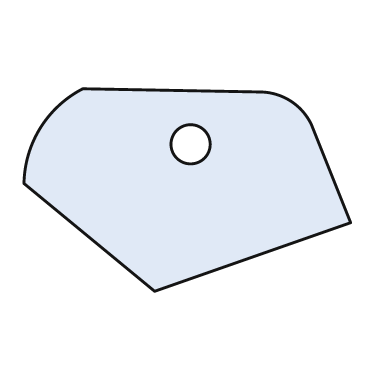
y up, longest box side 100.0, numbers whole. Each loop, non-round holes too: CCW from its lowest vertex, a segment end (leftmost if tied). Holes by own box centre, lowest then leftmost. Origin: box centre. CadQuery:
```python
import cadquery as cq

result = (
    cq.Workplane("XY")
    .moveTo(-10.0, -31.0)
    .lineTo(50.0, -10.0)
    .lineTo(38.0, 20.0)
    .threePointArc((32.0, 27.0), (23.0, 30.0))
    .lineTo(-32.0, 31.0)
    .threePointArc((-45.0, 19.0), (-50.0, 2.0))
    .close()
    .moveTo(1.0, 14.0)
    .circle(6.0)
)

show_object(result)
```